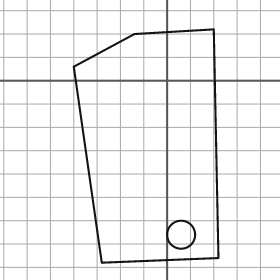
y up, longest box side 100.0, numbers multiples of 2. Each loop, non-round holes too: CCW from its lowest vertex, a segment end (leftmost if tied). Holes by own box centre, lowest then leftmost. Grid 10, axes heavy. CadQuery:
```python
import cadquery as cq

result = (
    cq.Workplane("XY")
    .moveTo(-28.0, -78.0)
    .lineTo(22.0, -76.0)
    .lineTo(20.0, 22.0)
    .lineTo(-14.0, 20.0)
    .lineTo(-40.0, 6.0)
    .close()
    .moveTo(6.0, -66.0)
    .circle(6.0)
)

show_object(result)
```